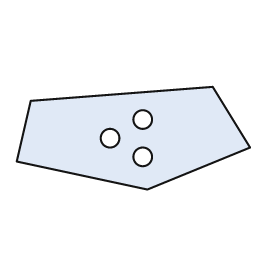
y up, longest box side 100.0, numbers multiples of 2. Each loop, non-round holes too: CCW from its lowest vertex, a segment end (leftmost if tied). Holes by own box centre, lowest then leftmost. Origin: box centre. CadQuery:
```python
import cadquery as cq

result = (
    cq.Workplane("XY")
    .moveTo(6.0, -22.0)
    .lineTo(50.0, -4.0)
    .lineTo(34.0, 22.0)
    .lineTo(-44.0, 16.0)
    .lineTo(-50.0, -10.0)
    .close()
    .moveTo(4.0, -8.0)
    .circle(4.0)
    .moveTo(-10.0, 0.0)
    .circle(4.0)
    .moveTo(4.0, 8.0)
    .circle(4.0)
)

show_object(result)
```